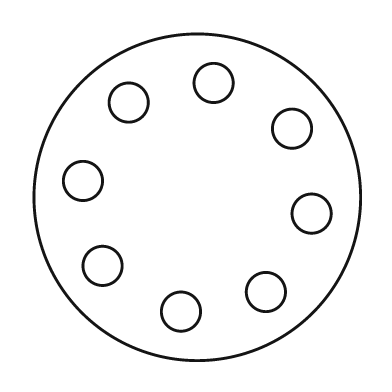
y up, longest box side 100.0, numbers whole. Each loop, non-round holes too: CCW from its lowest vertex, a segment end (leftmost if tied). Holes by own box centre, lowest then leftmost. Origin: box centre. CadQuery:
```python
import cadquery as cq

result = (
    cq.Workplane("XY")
    .moveTo(0.0, 0.0)
    .circle(50.0)
    .moveTo(-5.0, -35.0)
    .circle(6.0)
    .moveTo(21.0, -29.0)
    .circle(6.0)
    .moveTo(-29.0, -21.0)
    .circle(6.0)
    .moveTo(35.0, -5.0)
    .circle(6.0)
    .moveTo(-35.0, 5.0)
    .circle(6.0)
    .moveTo(29.0, 21.0)
    .circle(6.0)
    .moveTo(-21.0, 29.0)
    .circle(6.0)
    .moveTo(5.0, 35.0)
    .circle(6.0)
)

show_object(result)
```